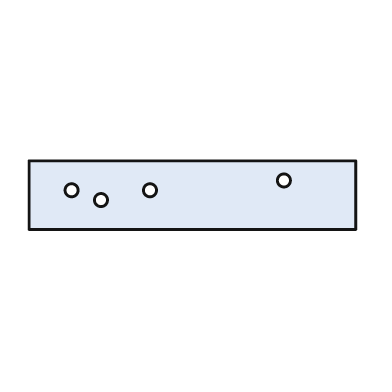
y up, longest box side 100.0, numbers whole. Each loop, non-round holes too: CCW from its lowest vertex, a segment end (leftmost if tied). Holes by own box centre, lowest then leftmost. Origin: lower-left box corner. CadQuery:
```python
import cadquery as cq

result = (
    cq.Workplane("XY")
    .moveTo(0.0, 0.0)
    .lineTo(100.0, 0.0)
    .lineTo(100.0, 21.0)
    .lineTo(0.0, 21.0)
    .close()
    .moveTo(22.0, 9.0)
    .circle(2.0)
    .moveTo(13.0, 12.0)
    .circle(2.0)
    .moveTo(37.0, 12.0)
    .circle(2.0)
    .moveTo(78.0, 15.0)
    .circle(2.0)
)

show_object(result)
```